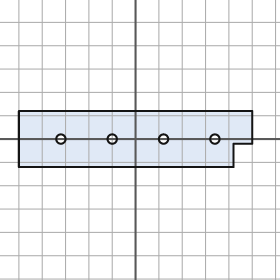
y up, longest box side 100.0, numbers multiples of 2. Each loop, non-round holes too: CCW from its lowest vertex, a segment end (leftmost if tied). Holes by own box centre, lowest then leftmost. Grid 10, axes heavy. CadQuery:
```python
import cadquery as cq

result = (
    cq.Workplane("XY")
    .moveTo(-50.0, -12.0)
    .lineTo(42.0, -12.0)
    .lineTo(42.0, -2.0)
    .lineTo(50.0, -2.0)
    .lineTo(50.0, 12.0)
    .lineTo(-50.0, 12.0)
    .close()
    .moveTo(-32.0, 0.0)
    .circle(2.0)
    .moveTo(-10.0, 0.0)
    .circle(2.0)
    .moveTo(12.0, 0.0)
    .circle(2.0)
    .moveTo(34.0, 0.0)
    .circle(2.0)
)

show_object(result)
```